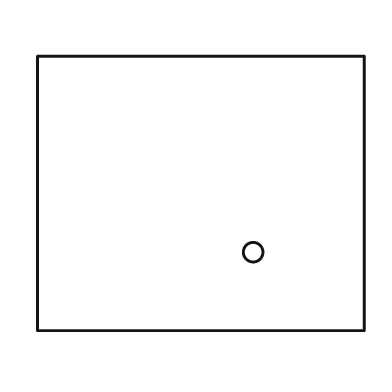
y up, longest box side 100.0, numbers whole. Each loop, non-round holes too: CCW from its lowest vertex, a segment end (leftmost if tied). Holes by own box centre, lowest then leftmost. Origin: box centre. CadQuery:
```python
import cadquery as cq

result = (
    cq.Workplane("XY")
    .moveTo(-50.0, -42.0)
    .lineTo(50.0, -42.0)
    .lineTo(50.0, 42.0)
    .lineTo(-50.0, 42.0)
    .close()
    .moveTo(16.0, -18.0)
    .circle(3.0)
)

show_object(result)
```